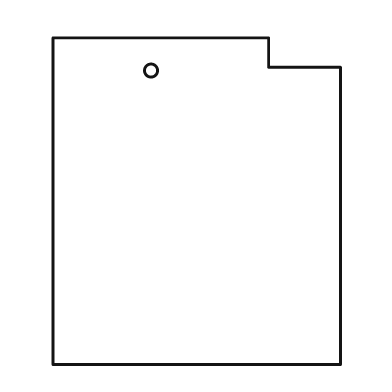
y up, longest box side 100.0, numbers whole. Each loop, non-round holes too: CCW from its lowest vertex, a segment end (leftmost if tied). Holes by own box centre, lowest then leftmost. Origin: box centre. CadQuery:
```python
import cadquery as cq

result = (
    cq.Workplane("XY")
    .moveTo(-44.0, -50.0)
    .lineTo(44.0, -50.0)
    .lineTo(44.0, 41.0)
    .lineTo(22.0, 41.0)
    .lineTo(22.0, 50.0)
    .lineTo(-44.0, 50.0)
    .close()
    .moveTo(-14.0, 40.0)
    .circle(2.0)
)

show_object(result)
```